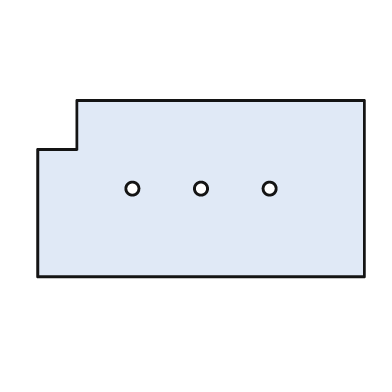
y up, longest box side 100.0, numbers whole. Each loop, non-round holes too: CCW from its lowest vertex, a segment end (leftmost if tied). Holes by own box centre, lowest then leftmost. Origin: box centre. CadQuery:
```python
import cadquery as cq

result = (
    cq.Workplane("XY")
    .moveTo(-50.0, -27.0)
    .lineTo(50.0, -27.0)
    .lineTo(50.0, 27.0)
    .lineTo(-38.0, 27.0)
    .lineTo(-38.0, 12.0)
    .lineTo(-50.0, 12.0)
    .close()
    .moveTo(-21.0, 0.0)
    .circle(2.0)
    .moveTo(0.0, 0.0)
    .circle(2.0)
    .moveTo(21.0, 0.0)
    .circle(2.0)
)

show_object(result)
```